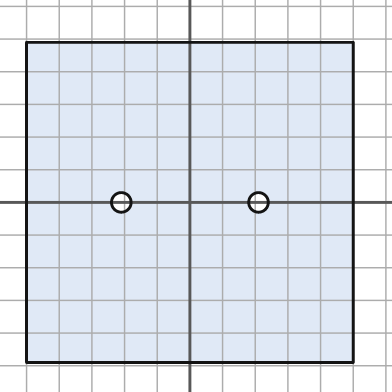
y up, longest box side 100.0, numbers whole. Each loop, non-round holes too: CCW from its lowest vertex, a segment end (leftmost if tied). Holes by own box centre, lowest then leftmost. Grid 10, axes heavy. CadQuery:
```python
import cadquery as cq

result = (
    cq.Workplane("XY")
    .moveTo(-50.0, -49.0)
    .lineTo(50.0, -49.0)
    .lineTo(50.0, 49.0)
    .lineTo(-50.0, 49.0)
    .close()
    .moveTo(-21.0, 0.0)
    .circle(3.0)
    .moveTo(21.0, 0.0)
    .circle(3.0)
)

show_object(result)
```